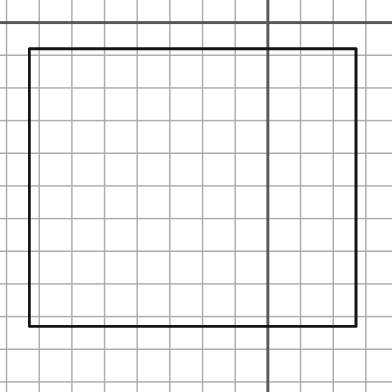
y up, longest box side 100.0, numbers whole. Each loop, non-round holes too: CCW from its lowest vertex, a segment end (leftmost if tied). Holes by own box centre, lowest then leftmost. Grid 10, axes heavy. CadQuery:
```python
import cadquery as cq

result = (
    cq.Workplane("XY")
    .moveTo(-73.0, -93.0)
    .lineTo(27.0, -93.0)
    .lineTo(27.0, -8.0)
    .lineTo(-73.0, -8.0)
    .close()
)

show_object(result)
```